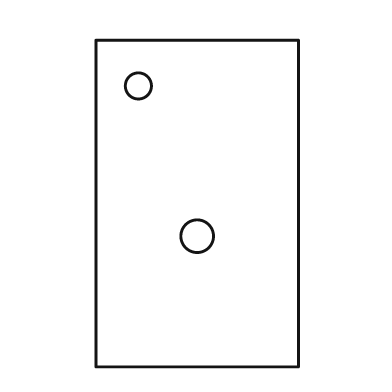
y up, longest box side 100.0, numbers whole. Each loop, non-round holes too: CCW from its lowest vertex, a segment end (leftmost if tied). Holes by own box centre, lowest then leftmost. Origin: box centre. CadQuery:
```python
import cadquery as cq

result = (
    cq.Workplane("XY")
    .moveTo(-31.0, -50.0)
    .lineTo(31.0, -50.0)
    .lineTo(31.0, 50.0)
    .lineTo(-31.0, 50.0)
    .close()
    .moveTo(0.0, -10.0)
    .circle(5.0)
    .moveTo(-18.0, 36.0)
    .circle(4.0)
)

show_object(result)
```